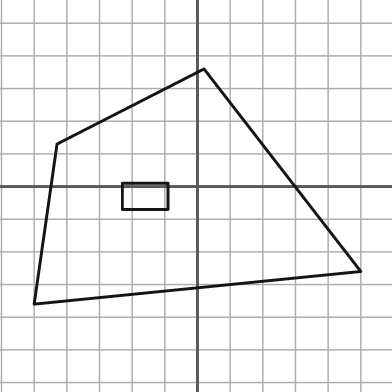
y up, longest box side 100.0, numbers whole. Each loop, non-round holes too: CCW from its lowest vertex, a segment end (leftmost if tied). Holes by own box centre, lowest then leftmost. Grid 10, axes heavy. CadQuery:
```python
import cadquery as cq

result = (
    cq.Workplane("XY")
    .moveTo(-50.0, -36.0)
    .lineTo(50.0, -26.0)
    .lineTo(2.0, 36.0)
    .lineTo(-43.0, 13.0)
    .close()
    .moveTo(-23.0, -7.0)
    .lineTo(-9.0, -7.0)
    .lineTo(-9.0, 1.0)
    .lineTo(-23.0, 1.0)
    .close()
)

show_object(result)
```